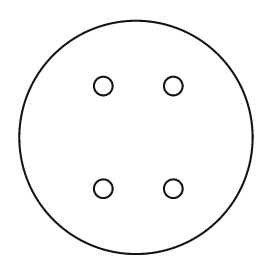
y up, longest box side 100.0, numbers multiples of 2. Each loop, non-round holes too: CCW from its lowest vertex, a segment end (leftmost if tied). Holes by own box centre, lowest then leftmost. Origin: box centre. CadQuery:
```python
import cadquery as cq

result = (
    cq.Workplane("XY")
    .moveTo(0.0, 0.0)
    .circle(50.0)
    .moveTo(-14.0, -22.0)
    .circle(4.0)
    .moveTo(16.0, -22.0)
    .circle(4.0)
    .moveTo(-14.0, 22.0)
    .circle(4.0)
    .moveTo(16.0, 22.0)
    .circle(4.0)
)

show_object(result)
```